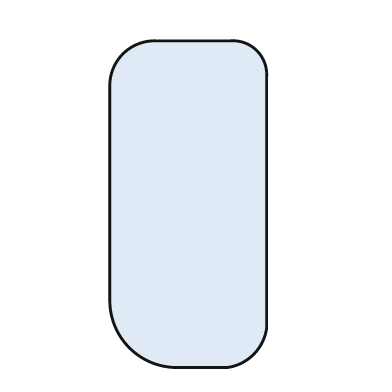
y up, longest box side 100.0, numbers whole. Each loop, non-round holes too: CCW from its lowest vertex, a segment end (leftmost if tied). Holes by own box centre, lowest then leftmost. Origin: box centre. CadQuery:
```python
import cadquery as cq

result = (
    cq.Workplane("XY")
    .moveTo(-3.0, -50.0)
    .lineTo(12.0, -50.0)
    .threePointArc((20.0, -46.0), (24.0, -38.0))
    .lineTo(24.0, 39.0)
    .threePointArc((21.0, 47.0), (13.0, 50.0))
    .lineTo(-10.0, 50.0)
    .threePointArc((-20.0, 46.0), (-24.0, 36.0))
    .lineTo(-24.0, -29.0)
    .threePointArc((-18.0, -44.0), (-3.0, -50.0))
    .close()
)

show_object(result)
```